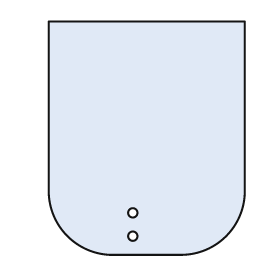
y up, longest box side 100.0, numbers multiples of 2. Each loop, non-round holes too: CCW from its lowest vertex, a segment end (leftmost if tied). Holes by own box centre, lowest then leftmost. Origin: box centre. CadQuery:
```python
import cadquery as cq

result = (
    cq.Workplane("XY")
    .moveTo(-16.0, -50.0)
    .lineTo(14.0, -50.0)
    .threePointArc((34.0, -42.0), (42.0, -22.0))
    .lineTo(42.0, 50.0)
    .lineTo(-42.0, 50.0)
    .lineTo(-42.0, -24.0)
    .threePointArc((-34.0, -42.0), (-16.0, -50.0))
    .close()
    .moveTo(-6.0, -42.0)
    .circle(2.0)
    .moveTo(-6.0, -32.0)
    .circle(2.0)
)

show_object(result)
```